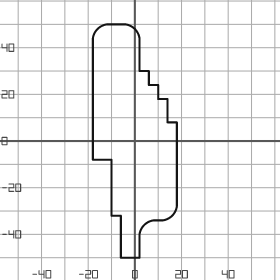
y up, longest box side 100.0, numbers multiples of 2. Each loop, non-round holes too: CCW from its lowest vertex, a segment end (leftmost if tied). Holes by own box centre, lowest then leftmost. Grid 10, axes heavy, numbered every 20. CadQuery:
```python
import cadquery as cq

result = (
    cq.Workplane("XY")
    .moveTo(-6.0, -50.0)
    .lineTo(2.0, -50.0)
    .lineTo(2.0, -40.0)
    .threePointArc((4.0, -36.0), (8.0, -34.0))
    .lineTo(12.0, -34.0)
    .threePointArc((16.0, -32.0), (18.0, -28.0))
    .lineTo(18.0, 8.0)
    .lineTo(14.0, 8.0)
    .lineTo(14.0, 18.0)
    .lineTo(10.0, 18.0)
    .lineTo(10.0, 24.0)
    .lineTo(6.0, 24.0)
    .lineTo(6.0, 30.0)
    .lineTo(2.0, 30.0)
    .lineTo(2.0, 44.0)
    .threePointArc((0.0, 48.0), (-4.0, 50.0))
    .lineTo(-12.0, 50.0)
    .threePointArc((-16.0, 48.0), (-18.0, 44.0))
    .lineTo(-18.0, -8.0)
    .lineTo(-10.0, -8.0)
    .lineTo(-10.0, -32.0)
    .lineTo(-6.0, -32.0)
    .close()
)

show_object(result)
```